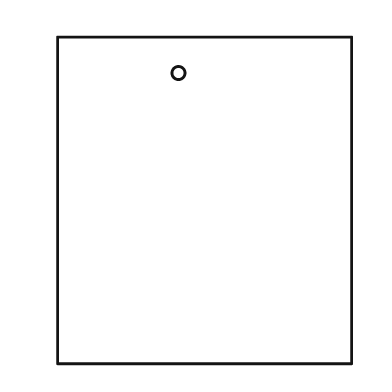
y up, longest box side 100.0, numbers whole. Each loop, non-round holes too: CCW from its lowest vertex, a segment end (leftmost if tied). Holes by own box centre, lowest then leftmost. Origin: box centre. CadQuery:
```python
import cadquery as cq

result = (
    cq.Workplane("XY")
    .moveTo(-45.0, -50.0)
    .lineTo(45.0, -50.0)
    .lineTo(45.0, 50.0)
    .lineTo(-45.0, 50.0)
    .close()
    .moveTo(-8.0, 39.0)
    .circle(2.0)
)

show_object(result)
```